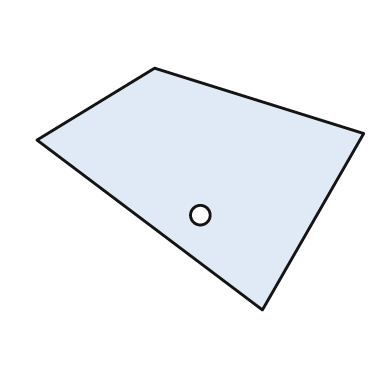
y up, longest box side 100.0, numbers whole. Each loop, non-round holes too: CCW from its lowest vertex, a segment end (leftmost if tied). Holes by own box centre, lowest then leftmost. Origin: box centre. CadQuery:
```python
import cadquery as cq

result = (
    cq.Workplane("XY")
    .moveTo(19.0, -37.0)
    .lineTo(50.0, 17.0)
    .lineTo(-14.0, 37.0)
    .lineTo(-50.0, 15.0)
    .close()
    .moveTo(0.0, -8.0)
    .circle(3.0)
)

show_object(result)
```